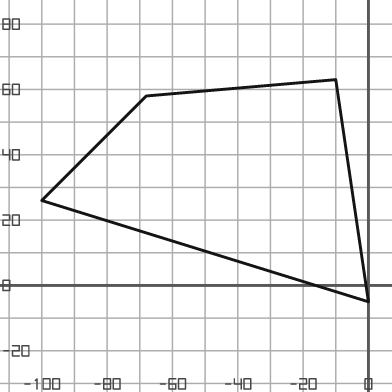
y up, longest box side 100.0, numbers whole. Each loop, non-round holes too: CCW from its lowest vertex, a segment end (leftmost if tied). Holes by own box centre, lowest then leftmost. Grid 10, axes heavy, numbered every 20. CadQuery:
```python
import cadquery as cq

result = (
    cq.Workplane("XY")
    .moveTo(0.0, -5.0)
    .lineTo(-10.0, 63.0)
    .lineTo(-68.0, 58.0)
    .lineTo(-100.0, 26.0)
    .close()
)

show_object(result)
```